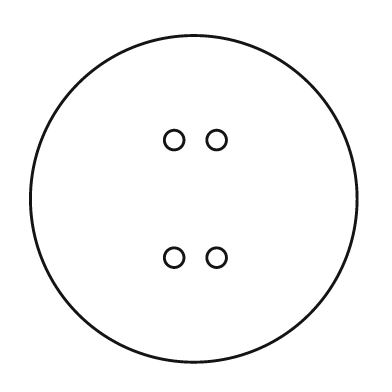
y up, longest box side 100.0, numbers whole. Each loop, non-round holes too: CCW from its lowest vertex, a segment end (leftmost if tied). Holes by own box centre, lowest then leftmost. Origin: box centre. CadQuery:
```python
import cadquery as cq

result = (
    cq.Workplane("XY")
    .moveTo(0.0, 0.0)
    .circle(50.0)
    .moveTo(-6.0, -18.0)
    .circle(3.0)
    .moveTo(7.0, -18.0)
    .circle(3.0)
    .moveTo(-6.0, 18.0)
    .circle(3.0)
    .moveTo(7.0, 18.0)
    .circle(3.0)
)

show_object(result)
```